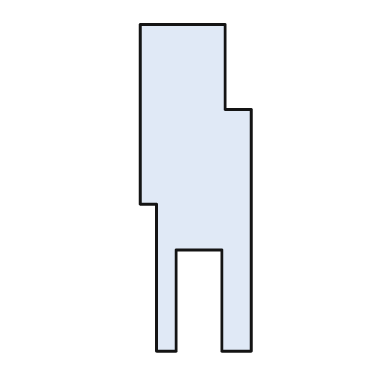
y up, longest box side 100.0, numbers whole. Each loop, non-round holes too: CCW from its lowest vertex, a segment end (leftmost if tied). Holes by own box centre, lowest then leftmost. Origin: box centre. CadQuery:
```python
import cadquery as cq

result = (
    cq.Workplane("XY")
    .moveTo(-12.0, -50.0)
    .lineTo(-6.0, -50.0)
    .lineTo(-6.0, -19.0)
    .lineTo(8.0, -19.0)
    .lineTo(8.0, -50.0)
    .lineTo(17.0, -50.0)
    .lineTo(17.0, 24.0)
    .lineTo(9.0, 24.0)
    .lineTo(9.0, 50.0)
    .lineTo(-17.0, 50.0)
    .lineTo(-17.0, -5.0)
    .lineTo(-12.0, -5.0)
    .close()
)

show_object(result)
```